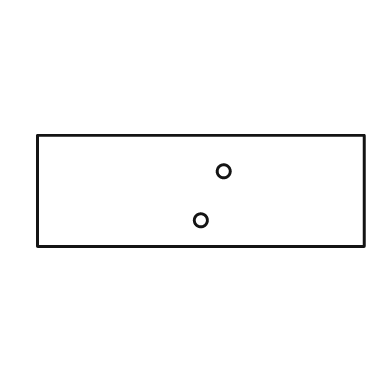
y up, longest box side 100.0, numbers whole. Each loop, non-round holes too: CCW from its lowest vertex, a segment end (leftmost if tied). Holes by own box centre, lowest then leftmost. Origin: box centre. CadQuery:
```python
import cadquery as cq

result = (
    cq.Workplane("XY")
    .moveTo(-50.0, -17.0)
    .lineTo(50.0, -17.0)
    .lineTo(50.0, 17.0)
    .lineTo(-50.0, 17.0)
    .close()
    .moveTo(0.0, -9.0)
    .circle(2.0)
    .moveTo(7.0, 6.0)
    .circle(2.0)
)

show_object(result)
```